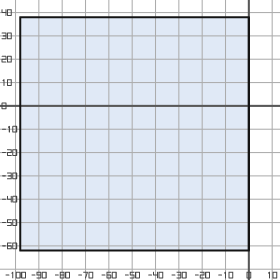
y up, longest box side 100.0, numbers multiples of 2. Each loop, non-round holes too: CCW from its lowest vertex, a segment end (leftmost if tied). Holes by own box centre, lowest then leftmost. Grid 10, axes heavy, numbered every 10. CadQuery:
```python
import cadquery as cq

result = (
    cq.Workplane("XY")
    .moveTo(-98.0, -62.0)
    .lineTo(0.0, -62.0)
    .lineTo(0.0, 38.0)
    .lineTo(-98.0, 38.0)
    .close()
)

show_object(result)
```